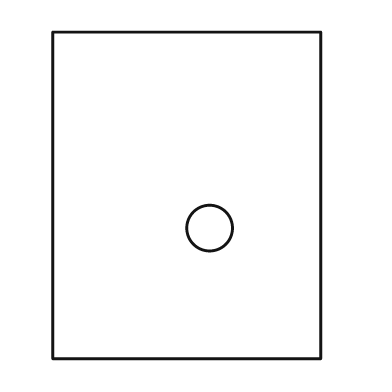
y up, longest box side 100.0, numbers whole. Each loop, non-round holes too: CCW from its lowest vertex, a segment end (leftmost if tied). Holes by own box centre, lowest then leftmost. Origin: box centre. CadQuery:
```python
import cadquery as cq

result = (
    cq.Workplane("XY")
    .moveTo(-41.0, -50.0)
    .lineTo(41.0, -50.0)
    .lineTo(41.0, 50.0)
    .lineTo(-41.0, 50.0)
    .close()
    .moveTo(7.0, -10.0)
    .circle(7.0)
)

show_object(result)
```